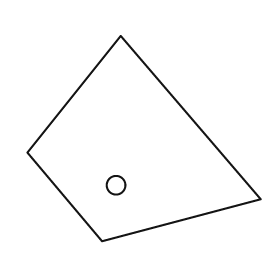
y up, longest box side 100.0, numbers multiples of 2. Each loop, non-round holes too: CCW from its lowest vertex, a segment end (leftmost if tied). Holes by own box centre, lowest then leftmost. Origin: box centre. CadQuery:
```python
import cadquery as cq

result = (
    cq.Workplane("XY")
    .moveTo(-18.0, -44.0)
    .lineTo(50.0, -26.0)
    .lineTo(-10.0, 44.0)
    .lineTo(-50.0, -6.0)
    .close()
    .moveTo(-12.0, -20.0)
    .circle(4.0)
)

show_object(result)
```